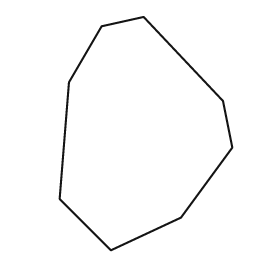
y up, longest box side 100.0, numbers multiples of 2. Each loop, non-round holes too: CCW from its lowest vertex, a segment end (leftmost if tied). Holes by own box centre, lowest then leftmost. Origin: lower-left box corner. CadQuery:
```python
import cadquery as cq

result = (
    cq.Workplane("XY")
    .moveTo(22.0, 0.0)
    .lineTo(52.0, 14.0)
    .lineTo(74.0, 44.0)
    .lineTo(70.0, 64.0)
    .lineTo(36.0, 100.0)
    .lineTo(18.0, 96.0)
    .lineTo(4.0, 72.0)
    .lineTo(0.0, 22.0)
    .close()
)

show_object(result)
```